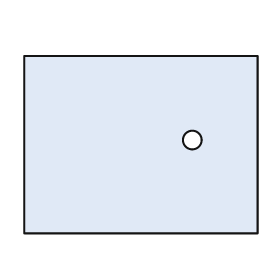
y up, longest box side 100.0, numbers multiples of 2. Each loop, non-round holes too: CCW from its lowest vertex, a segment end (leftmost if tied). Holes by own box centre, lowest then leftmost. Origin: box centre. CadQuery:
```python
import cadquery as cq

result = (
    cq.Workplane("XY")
    .moveTo(-50.0, -38.0)
    .lineTo(50.0, -38.0)
    .lineTo(50.0, 38.0)
    .lineTo(-50.0, 38.0)
    .close()
    .moveTo(22.0, 2.0)
    .circle(4.0)
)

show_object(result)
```